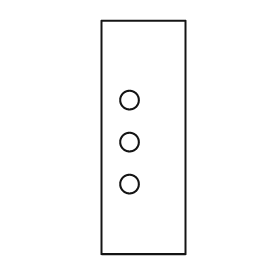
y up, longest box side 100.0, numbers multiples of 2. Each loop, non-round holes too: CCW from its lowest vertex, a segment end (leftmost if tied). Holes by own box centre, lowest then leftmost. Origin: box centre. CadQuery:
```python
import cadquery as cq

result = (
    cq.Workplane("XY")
    .moveTo(-18.0, -50.0)
    .lineTo(18.0, -50.0)
    .lineTo(18.0, 50.0)
    .lineTo(-18.0, 50.0)
    .close()
    .moveTo(-6.0, -20.0)
    .circle(4.0)
    .moveTo(-6.0, -2.0)
    .circle(4.0)
    .moveTo(-6.0, 16.0)
    .circle(4.0)
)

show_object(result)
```